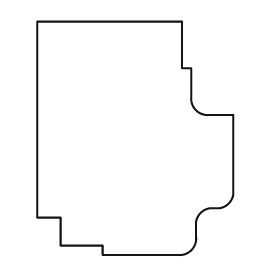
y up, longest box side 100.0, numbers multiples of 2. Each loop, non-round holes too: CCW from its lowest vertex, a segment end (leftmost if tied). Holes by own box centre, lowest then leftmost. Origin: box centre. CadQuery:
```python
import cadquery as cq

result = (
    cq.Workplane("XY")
    .moveTo(-14.0, -50.0)
    .lineTo(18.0, -50.0)
    .threePointArc((24.0, -48.0), (26.0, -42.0))
    .lineTo(26.0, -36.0)
    .threePointArc((28.0, -32.0), (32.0, -30.0))
    .lineTo(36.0, -30.0)
    .threePointArc((40.0, -28.0), (42.0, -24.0))
    .lineTo(42.0, 10.0)
    .lineTo(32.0, 10.0)
    .threePointArc((26.0, 12.0), (24.0, 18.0))
    .lineTo(24.0, 30.0)
    .lineTo(20.0, 30.0)
    .lineTo(20.0, 50.0)
    .lineTo(-42.0, 50.0)
    .lineTo(-42.0, -34.0)
    .lineTo(-32.0, -34.0)
    .lineTo(-32.0, -46.0)
    .lineTo(-14.0, -46.0)
    .close()
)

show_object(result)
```